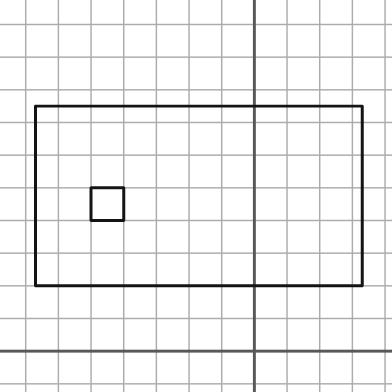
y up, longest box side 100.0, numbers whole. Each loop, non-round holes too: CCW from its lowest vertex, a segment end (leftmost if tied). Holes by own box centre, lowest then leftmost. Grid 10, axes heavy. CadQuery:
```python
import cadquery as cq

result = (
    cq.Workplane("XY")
    .moveTo(-67.0, 20.0)
    .lineTo(33.0, 20.0)
    .lineTo(33.0, 75.0)
    .lineTo(-67.0, 75.0)
    .close()
    .moveTo(-50.0, 40.0)
    .lineTo(-40.0, 40.0)
    .lineTo(-40.0, 50.0)
    .lineTo(-50.0, 50.0)
    .close()
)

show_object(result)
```